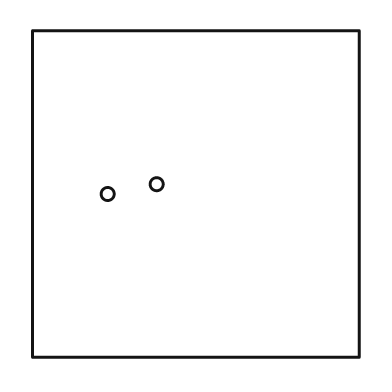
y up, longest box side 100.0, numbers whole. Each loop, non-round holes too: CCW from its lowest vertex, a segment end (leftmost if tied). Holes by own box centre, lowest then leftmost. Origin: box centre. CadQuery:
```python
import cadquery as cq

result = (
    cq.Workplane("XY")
    .moveTo(-50.0, -50.0)
    .lineTo(50.0, -50.0)
    .lineTo(50.0, 50.0)
    .lineTo(-50.0, 50.0)
    .close()
    .moveTo(-27.0, 0.0)
    .circle(2.0)
    .moveTo(-12.0, 3.0)
    .circle(2.0)
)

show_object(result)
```